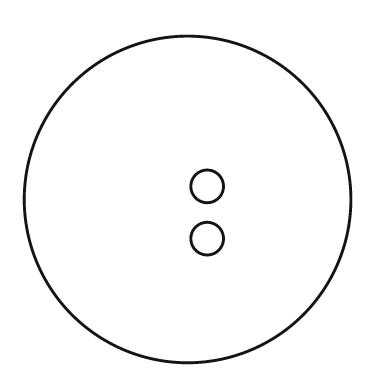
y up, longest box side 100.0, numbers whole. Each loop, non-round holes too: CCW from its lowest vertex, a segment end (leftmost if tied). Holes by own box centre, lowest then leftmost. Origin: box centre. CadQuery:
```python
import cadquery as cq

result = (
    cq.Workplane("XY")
    .moveTo(0.0, 0.0)
    .circle(50.0)
    .moveTo(6.0, -12.0)
    .circle(5.0)
    .moveTo(6.0, 4.0)
    .circle(5.0)
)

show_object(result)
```